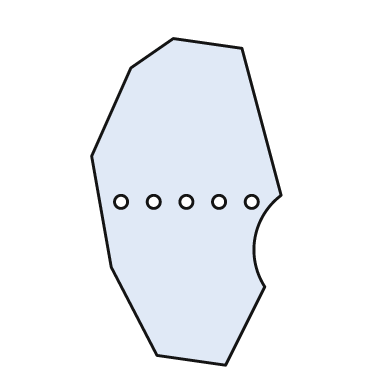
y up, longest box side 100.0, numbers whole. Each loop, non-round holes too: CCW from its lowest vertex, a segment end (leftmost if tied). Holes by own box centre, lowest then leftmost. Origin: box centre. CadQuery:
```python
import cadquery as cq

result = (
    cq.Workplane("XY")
    .moveTo(12.0, -50.0)
    .lineTo(24.0, -26.0)
    .threePointArc((21.0, -11.0), (29.0, 2.0))
    .lineTo(17.0, 47.0)
    .lineTo(-4.0, 50.0)
    .lineTo(-17.0, 41.0)
    .lineTo(-29.0, 14.0)
    .lineTo(-23.0, -20.0)
    .lineTo(-9.0, -47.0)
    .close()
    .moveTo(-20.0, 0.0)
    .circle(2.0)
    .moveTo(-10.0, 0.0)
    .circle(2.0)
    .moveTo(0.0, 0.0)
    .circle(2.0)
    .moveTo(10.0, 0.0)
    .circle(2.0)
    .moveTo(20.0, 0.0)
    .circle(2.0)
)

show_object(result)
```